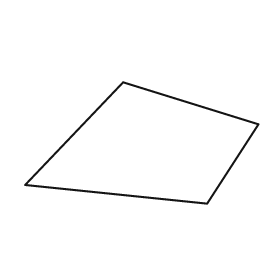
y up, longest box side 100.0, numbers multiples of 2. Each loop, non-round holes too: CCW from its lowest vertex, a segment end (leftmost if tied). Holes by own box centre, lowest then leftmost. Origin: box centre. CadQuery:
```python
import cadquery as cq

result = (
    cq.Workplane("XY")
    .moveTo(28.0, -26.0)
    .lineTo(50.0, 8.0)
    .lineTo(-8.0, 26.0)
    .lineTo(-50.0, -18.0)
    .close()
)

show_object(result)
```